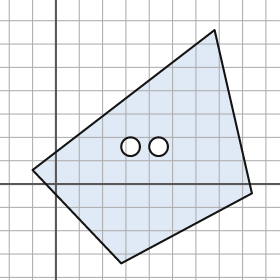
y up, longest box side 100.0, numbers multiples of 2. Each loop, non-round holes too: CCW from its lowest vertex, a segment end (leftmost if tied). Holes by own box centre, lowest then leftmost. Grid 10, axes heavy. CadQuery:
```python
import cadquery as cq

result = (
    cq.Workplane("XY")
    .moveTo(28.0, -34.0)
    .lineTo(84.0, -4.0)
    .lineTo(68.0, 66.0)
    .lineTo(-10.0, 6.0)
    .close()
    .moveTo(32.0, 16.0)
    .circle(4.0)
    .moveTo(44.0, 16.0)
    .circle(4.0)
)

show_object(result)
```